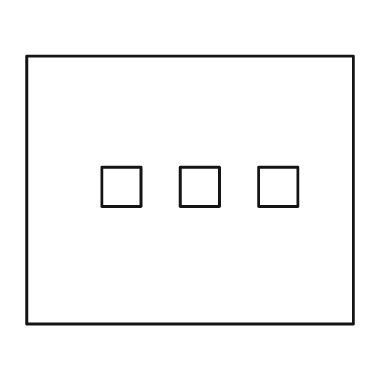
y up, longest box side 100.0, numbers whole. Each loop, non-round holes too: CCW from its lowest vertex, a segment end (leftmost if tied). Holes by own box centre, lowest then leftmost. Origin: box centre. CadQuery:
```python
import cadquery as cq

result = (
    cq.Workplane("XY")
    .moveTo(-50.0, -41.0)
    .lineTo(50.0, -41.0)
    .lineTo(50.0, 41.0)
    .lineTo(-50.0, 41.0)
    .close()
    .moveTo(-27.0, -5.0)
    .lineTo(-15.0, -5.0)
    .lineTo(-15.0, 7.0)
    .lineTo(-27.0, 7.0)
    .close()
    .moveTo(-3.0, -5.0)
    .lineTo(9.0, -5.0)
    .lineTo(9.0, 7.0)
    .lineTo(-3.0, 7.0)
    .close()
    .moveTo(21.0, -5.0)
    .lineTo(33.0, -5.0)
    .lineTo(33.0, 7.0)
    .lineTo(21.0, 7.0)
    .close()
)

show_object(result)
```